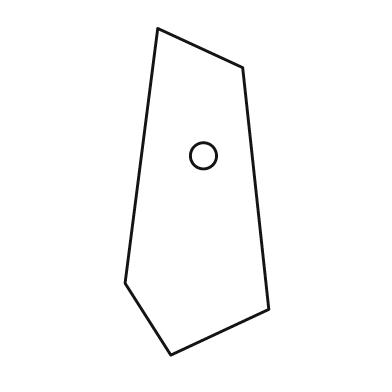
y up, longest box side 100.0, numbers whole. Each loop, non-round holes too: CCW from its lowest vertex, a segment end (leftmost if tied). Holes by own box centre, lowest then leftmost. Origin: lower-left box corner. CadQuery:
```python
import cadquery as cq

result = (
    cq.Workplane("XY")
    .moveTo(14.0, 0.0)
    .lineTo(44.0, 14.0)
    .lineTo(36.0, 88.0)
    .lineTo(10.0, 100.0)
    .lineTo(0.0, 22.0)
    .close()
    .moveTo(24.0, 61.0)
    .circle(4.0)
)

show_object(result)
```